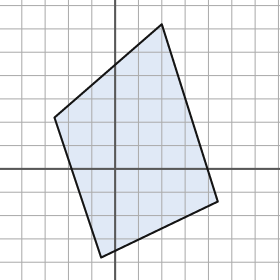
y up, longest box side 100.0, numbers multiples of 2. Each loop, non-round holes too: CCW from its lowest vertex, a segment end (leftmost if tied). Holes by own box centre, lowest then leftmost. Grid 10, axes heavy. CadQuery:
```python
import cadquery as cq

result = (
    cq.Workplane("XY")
    .moveTo(-6.0, -38.0)
    .lineTo(44.0, -14.0)
    .lineTo(20.0, 62.0)
    .lineTo(-26.0, 22.0)
    .close()
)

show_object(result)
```